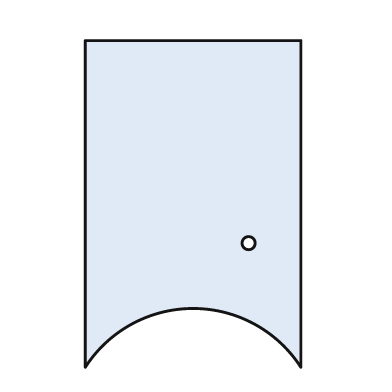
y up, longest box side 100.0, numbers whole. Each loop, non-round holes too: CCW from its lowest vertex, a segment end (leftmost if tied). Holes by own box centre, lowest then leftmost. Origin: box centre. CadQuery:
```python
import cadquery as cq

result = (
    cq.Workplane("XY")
    .moveTo(-33.0, -50.0)
    .threePointArc((0.0, -32.0), (33.0, -50.0))
    .lineTo(33.0, 50.0)
    .lineTo(-33.0, 50.0)
    .close()
    .moveTo(17.0, -12.0)
    .circle(2.0)
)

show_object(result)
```